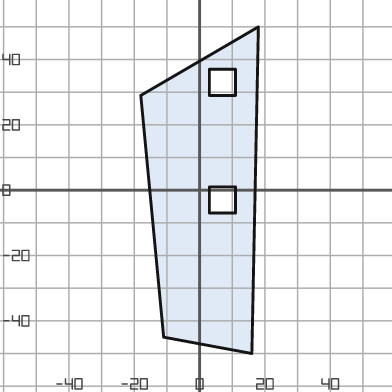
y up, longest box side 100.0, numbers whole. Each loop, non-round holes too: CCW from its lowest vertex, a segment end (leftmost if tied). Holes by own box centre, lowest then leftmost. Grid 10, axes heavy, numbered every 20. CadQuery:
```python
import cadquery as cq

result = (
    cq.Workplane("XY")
    .moveTo(16.0, -50.0)
    .lineTo(18.0, 50.0)
    .lineTo(-18.0, 29.0)
    .lineTo(-11.0, -45.0)
    .close()
    .moveTo(3.0, -7.0)
    .lineTo(11.0, -7.0)
    .lineTo(11.0, 1.0)
    .lineTo(3.0, 1.0)
    .close()
    .moveTo(3.0, 29.0)
    .lineTo(11.0, 29.0)
    .lineTo(11.0, 37.0)
    .lineTo(3.0, 37.0)
    .close()
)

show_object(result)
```